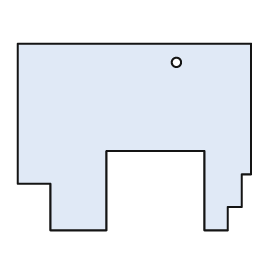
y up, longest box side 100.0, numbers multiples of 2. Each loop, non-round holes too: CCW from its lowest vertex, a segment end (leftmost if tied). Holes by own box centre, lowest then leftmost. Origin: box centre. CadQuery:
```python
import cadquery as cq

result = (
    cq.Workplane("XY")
    .moveTo(-36.0, -40.0)
    .lineTo(-12.0, -40.0)
    .lineTo(-12.0, -6.0)
    .lineTo(30.0, -6.0)
    .lineTo(30.0, -40.0)
    .lineTo(40.0, -40.0)
    .lineTo(40.0, -30.0)
    .lineTo(46.0, -30.0)
    .lineTo(46.0, -16.0)
    .lineTo(50.0, -16.0)
    .lineTo(50.0, 40.0)
    .lineTo(-50.0, 40.0)
    .lineTo(-50.0, -20.0)
    .lineTo(-36.0, -20.0)
    .close()
    .moveTo(18.0, 32.0)
    .circle(2.0)
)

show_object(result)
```